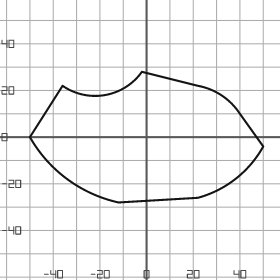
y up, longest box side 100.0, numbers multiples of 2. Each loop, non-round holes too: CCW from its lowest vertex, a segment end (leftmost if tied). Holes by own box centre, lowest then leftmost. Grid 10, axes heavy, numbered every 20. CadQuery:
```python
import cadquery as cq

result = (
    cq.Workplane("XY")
    .moveTo(-12.0, -28.0)
    .lineTo(22.0, -26.0)
    .threePointArc((38.0, -18.0), (50.0, -4.0))
    .lineTo(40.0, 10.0)
    .threePointArc((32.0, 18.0), (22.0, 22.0))
    .lineTo(-2.0, 28.0)
    .threePointArc((-18.0, 18.0), (-36.0, 22.0))
    .lineTo(-50.0, 0.0)
    .threePointArc((-34.0, -18.0), (-12.0, -28.0))
    .close()
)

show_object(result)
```